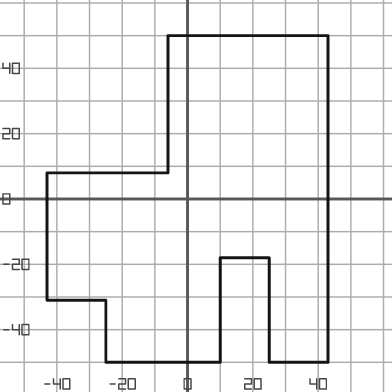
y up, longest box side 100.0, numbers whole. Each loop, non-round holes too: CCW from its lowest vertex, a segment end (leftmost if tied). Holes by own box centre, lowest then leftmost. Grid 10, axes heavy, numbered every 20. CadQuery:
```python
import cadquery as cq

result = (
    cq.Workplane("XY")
    .moveTo(-25.0, -50.0)
    .lineTo(10.0, -50.0)
    .lineTo(10.0, -18.0)
    .lineTo(25.0, -18.0)
    .lineTo(25.0, -50.0)
    .lineTo(43.0, -50.0)
    .lineTo(43.0, 50.0)
    .lineTo(-6.0, 50.0)
    .lineTo(-6.0, 8.0)
    .lineTo(-43.0, 8.0)
    .lineTo(-43.0, -31.0)
    .lineTo(-25.0, -31.0)
    .close()
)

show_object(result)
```